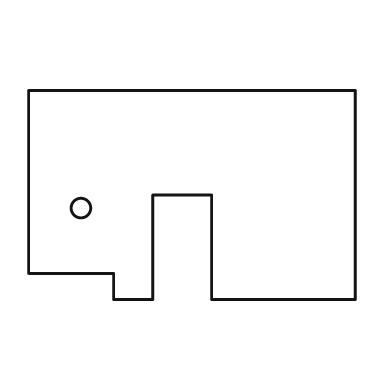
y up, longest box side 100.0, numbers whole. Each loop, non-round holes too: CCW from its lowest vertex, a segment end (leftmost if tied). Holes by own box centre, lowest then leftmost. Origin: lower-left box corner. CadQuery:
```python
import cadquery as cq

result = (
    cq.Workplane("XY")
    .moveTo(26.0, 0.0)
    .lineTo(38.0, 0.0)
    .lineTo(38.0, 32.0)
    .lineTo(56.0, 32.0)
    .lineTo(56.0, 0.0)
    .lineTo(100.0, 0.0)
    .lineTo(100.0, 64.0)
    .lineTo(0.0, 64.0)
    .lineTo(0.0, 8.0)
    .lineTo(26.0, 8.0)
    .close()
    .moveTo(16.0, 28.0)
    .circle(3.0)
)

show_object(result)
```